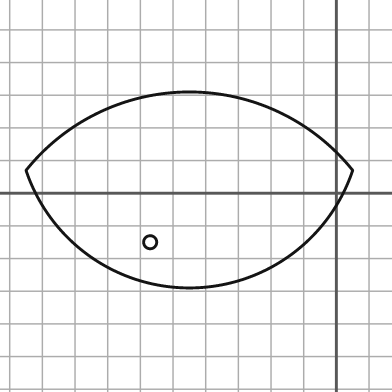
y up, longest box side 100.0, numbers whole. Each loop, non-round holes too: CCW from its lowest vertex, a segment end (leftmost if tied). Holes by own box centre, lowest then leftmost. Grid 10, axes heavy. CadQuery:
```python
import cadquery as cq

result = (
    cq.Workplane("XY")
    .moveTo(-95.0, 7.0)
    .threePointArc((-45.0, -29.0), (5.0, 7.0))
    .threePointArc((-45.0, 31.0), (-95.0, 7.0))
    .close()
    .moveTo(-57.0, -15.0)
    .circle(2.0)
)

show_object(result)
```